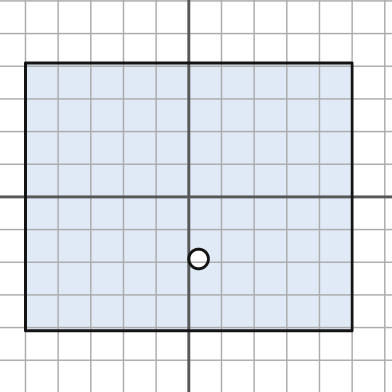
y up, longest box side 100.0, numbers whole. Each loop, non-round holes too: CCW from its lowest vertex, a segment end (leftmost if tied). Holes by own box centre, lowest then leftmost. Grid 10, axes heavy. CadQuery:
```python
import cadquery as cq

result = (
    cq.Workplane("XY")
    .moveTo(-50.0, -41.0)
    .lineTo(50.0, -41.0)
    .lineTo(50.0, 41.0)
    .lineTo(-50.0, 41.0)
    .close()
    .moveTo(3.0, -19.0)
    .circle(3.0)
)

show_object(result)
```